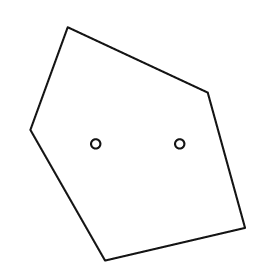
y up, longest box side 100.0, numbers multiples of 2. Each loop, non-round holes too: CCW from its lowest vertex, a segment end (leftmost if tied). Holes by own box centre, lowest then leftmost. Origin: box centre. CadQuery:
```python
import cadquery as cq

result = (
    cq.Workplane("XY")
    .moveTo(-14.0, -50.0)
    .lineTo(46.0, -36.0)
    .lineTo(30.0, 22.0)
    .lineTo(-30.0, 50.0)
    .lineTo(-46.0, 6.0)
    .close()
    .moveTo(-18.0, 0.0)
    .circle(2.0)
    .moveTo(18.0, 0.0)
    .circle(2.0)
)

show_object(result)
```